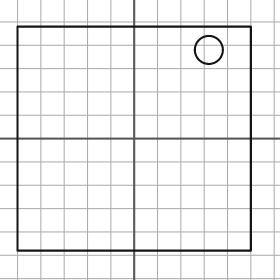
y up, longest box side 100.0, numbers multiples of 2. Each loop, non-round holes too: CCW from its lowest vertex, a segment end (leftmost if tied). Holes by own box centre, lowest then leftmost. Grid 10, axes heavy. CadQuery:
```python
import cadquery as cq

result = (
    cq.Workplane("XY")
    .moveTo(-50.0, -48.0)
    .lineTo(50.0, -48.0)
    .lineTo(50.0, 48.0)
    .lineTo(-50.0, 48.0)
    .close()
    .moveTo(32.0, 38.0)
    .circle(6.0)
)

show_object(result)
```